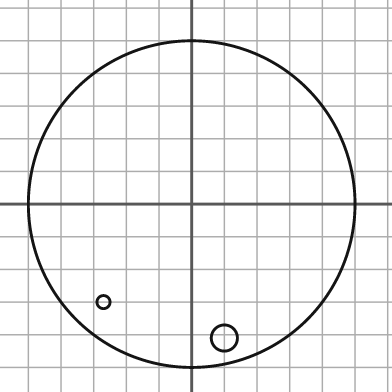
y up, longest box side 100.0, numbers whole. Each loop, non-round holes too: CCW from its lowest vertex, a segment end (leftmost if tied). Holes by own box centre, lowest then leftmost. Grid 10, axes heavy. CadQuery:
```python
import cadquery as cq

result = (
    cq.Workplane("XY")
    .moveTo(0.0, 0.0)
    .circle(50.0)
    .moveTo(10.0, -41.0)
    .circle(4.0)
    .moveTo(-27.0, -30.0)
    .circle(2.0)
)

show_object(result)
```